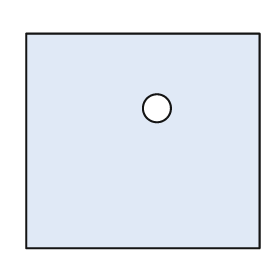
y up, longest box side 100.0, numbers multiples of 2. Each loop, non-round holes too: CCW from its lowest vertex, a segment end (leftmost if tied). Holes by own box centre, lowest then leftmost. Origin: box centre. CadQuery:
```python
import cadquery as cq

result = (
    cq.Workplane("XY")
    .moveTo(-50.0, -46.0)
    .lineTo(50.0, -46.0)
    .lineTo(50.0, 46.0)
    .lineTo(-50.0, 46.0)
    .close()
    .moveTo(6.0, 14.0)
    .circle(6.0)
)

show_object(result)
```